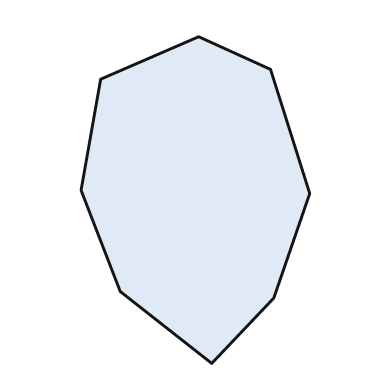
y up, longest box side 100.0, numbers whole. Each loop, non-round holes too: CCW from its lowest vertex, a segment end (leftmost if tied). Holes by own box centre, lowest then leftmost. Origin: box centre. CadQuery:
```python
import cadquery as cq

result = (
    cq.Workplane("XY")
    .moveTo(5.0, -50.0)
    .lineTo(24.0, -30.0)
    .lineTo(35.0, 2.0)
    .lineTo(23.0, 40.0)
    .lineTo(1.0, 50.0)
    .lineTo(-29.0, 37.0)
    .lineTo(-35.0, 3.0)
    .lineTo(-23.0, -28.0)
    .close()
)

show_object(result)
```